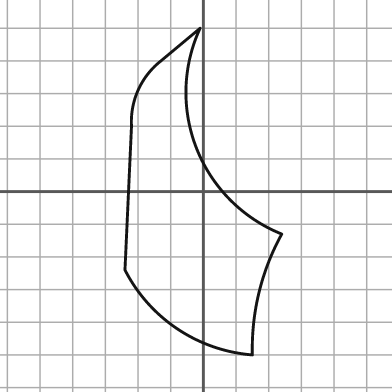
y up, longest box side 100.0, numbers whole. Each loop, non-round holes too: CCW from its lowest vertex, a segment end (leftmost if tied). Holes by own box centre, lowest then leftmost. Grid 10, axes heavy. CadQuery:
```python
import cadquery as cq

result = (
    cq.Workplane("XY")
    .moveTo(15.0, -50.0)
    .threePointArc((17.0, -31.0), (24.0, -13.0))
    .threePointArc((-2.0, 13.0), (-1.0, 50.0))
    .lineTo(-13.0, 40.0)
    .threePointArc((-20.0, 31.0), (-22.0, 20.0))
    .lineTo(-24.0, -24.0)
    .threePointArc((-8.0, -42.0), (15.0, -50.0))
    .close()
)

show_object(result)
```